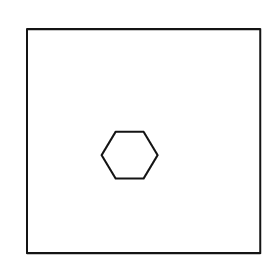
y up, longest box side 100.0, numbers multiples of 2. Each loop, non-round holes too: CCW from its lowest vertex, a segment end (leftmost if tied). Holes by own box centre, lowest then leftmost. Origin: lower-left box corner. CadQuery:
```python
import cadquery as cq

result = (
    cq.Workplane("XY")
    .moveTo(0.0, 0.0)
    .lineTo(100.0, 0.0)
    .lineTo(100.0, 96.0)
    .lineTo(0.0, 96.0)
    .close()
    .moveTo(38.0, 32.0)
    .lineTo(50.0, 32.0)
    .lineTo(56.0, 42.0)
    .lineTo(50.0, 52.0)
    .lineTo(38.0, 52.0)
    .lineTo(32.0, 42.0)
    .close()
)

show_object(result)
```